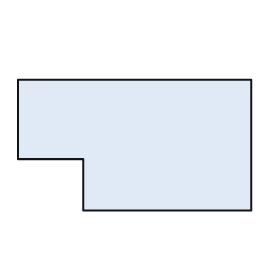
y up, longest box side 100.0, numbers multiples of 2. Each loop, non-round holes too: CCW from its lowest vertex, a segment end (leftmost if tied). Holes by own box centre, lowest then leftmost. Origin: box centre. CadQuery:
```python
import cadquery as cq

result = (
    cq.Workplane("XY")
    .moveTo(-22.0, -28.0)
    .lineTo(50.0, -28.0)
    .lineTo(50.0, 28.0)
    .lineTo(-50.0, 28.0)
    .lineTo(-50.0, -6.0)
    .lineTo(-22.0, -6.0)
    .close()
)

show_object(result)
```